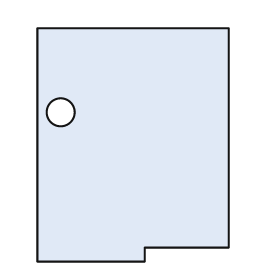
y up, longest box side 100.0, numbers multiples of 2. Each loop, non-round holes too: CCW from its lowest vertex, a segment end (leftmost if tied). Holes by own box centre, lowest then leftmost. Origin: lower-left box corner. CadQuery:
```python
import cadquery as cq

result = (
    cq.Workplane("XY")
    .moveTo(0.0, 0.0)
    .lineTo(46.0, 0.0)
    .lineTo(46.0, 6.0)
    .lineTo(82.0, 6.0)
    .lineTo(82.0, 100.0)
    .lineTo(0.0, 100.0)
    .close()
    .moveTo(10.0, 64.0)
    .circle(6.0)
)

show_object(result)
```